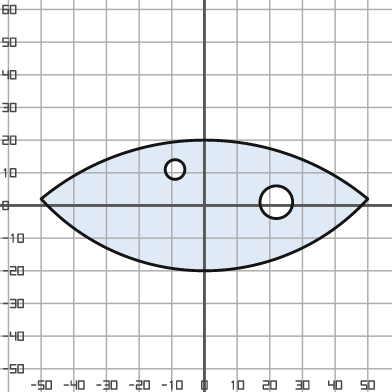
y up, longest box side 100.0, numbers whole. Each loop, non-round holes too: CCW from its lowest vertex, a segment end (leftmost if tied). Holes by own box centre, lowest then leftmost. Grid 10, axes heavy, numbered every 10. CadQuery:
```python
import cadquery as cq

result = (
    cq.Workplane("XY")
    .moveTo(-50.0, 2.0)
    .threePointArc((0.0, -20.0), (50.0, 2.0))
    .threePointArc((0.0, 20.0), (-50.0, 2.0))
    .close()
    .moveTo(22.0, 1.0)
    .circle(5.0)
    .moveTo(-9.0, 11.0)
    .circle(3.0)
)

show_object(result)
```